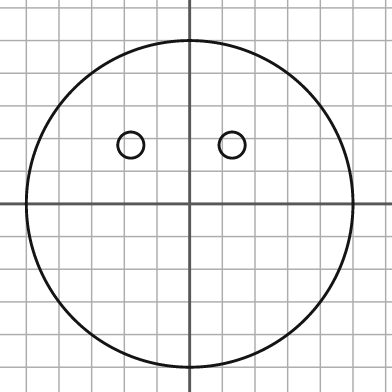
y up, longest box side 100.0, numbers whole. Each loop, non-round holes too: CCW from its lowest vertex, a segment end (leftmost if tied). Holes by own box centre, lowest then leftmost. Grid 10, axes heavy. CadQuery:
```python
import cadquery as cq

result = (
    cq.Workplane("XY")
    .moveTo(0.0, 0.0)
    .circle(50.0)
    .moveTo(-18.0, 18.0)
    .circle(4.0)
    .moveTo(13.0, 18.0)
    .circle(4.0)
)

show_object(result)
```